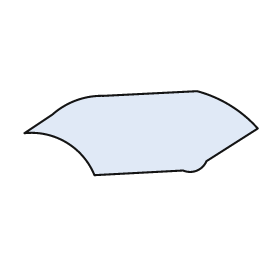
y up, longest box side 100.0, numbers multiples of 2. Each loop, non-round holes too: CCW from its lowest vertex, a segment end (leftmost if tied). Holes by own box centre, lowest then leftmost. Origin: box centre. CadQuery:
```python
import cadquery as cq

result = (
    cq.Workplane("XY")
    .moveTo(-20.0, -18.0)
    .lineTo(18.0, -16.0)
    .threePointArc((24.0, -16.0), (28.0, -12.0))
    .lineTo(50.0, 2.0)
    .threePointArc((38.0, 12.0), (24.0, 18.0))
    .lineTo(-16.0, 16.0)
    .threePointArc((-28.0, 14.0), (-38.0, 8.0))
    .lineTo(-50.0, 0.0)
    .threePointArc((-32.0, -4.0), (-20.0, -18.0))
    .close()
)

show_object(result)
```